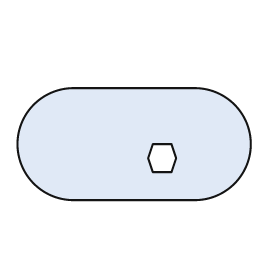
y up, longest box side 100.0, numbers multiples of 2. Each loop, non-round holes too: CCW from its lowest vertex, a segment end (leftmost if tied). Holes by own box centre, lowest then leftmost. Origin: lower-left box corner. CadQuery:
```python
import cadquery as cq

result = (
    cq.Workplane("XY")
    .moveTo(24.0, 0.0)
    .lineTo(76.0, 0.0)
    .threePointArc((100.0, 24.0), (76.0, 48.0))
    .lineTo(24.0, 48.0)
    .threePointArc((0.0, 24.0), (24.0, 0.0))
    .close()
    .moveTo(58.0, 12.0)
    .lineTo(66.0, 12.0)
    .lineTo(68.0, 18.0)
    .lineTo(66.0, 24.0)
    .lineTo(58.0, 24.0)
    .lineTo(56.0, 18.0)
    .close()
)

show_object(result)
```